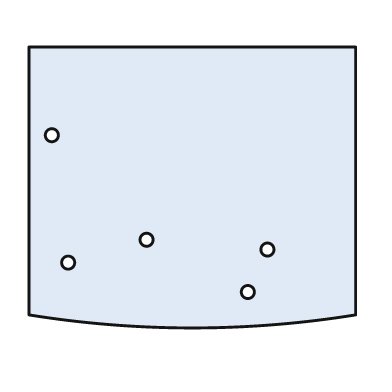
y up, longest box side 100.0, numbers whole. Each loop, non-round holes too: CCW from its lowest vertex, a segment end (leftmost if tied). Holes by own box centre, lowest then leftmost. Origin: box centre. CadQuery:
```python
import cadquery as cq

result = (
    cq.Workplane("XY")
    .moveTo(-50.0, -39.0)
    .threePointArc((0.0, -43.0), (50.0, -39.0))
    .lineTo(50.0, 43.0)
    .lineTo(-50.0, 43.0)
    .close()
    .moveTo(17.0, -32.0)
    .circle(2.0)
    .moveTo(-38.0, -23.0)
    .circle(2.0)
    .moveTo(23.0, -19.0)
    .circle(2.0)
    .moveTo(-14.0, -16.0)
    .circle(2.0)
    .moveTo(-43.0, 16.0)
    .circle(2.0)
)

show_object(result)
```